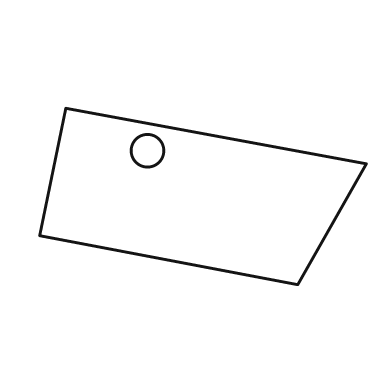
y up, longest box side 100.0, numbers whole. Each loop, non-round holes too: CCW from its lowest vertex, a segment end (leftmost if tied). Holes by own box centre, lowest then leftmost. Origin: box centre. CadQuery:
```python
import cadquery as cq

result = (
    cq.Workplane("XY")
    .moveTo(29.0, -27.0)
    .lineTo(50.0, 10.0)
    .lineTo(-42.0, 27.0)
    .lineTo(-50.0, -12.0)
    .close()
    .moveTo(-17.0, 14.0)
    .circle(5.0)
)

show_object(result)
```